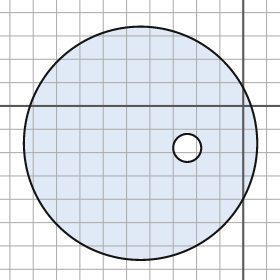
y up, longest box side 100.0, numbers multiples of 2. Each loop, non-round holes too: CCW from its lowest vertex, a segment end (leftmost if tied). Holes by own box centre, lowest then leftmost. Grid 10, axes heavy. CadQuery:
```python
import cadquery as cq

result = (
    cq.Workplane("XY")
    .moveTo(-44.0, -16.0)
    .circle(50.0)
    .moveTo(-24.0, -18.0)
    .circle(6.0)
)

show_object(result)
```